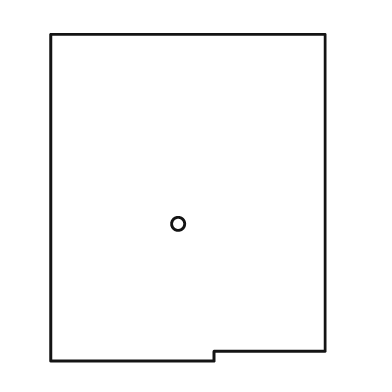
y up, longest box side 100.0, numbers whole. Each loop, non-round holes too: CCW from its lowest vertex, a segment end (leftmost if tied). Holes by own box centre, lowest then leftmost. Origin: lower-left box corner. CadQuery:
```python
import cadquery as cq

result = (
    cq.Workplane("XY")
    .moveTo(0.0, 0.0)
    .lineTo(50.0, 0.0)
    .lineTo(50.0, 3.0)
    .lineTo(84.0, 3.0)
    .lineTo(84.0, 100.0)
    .lineTo(0.0, 100.0)
    .close()
    .moveTo(39.0, 42.0)
    .circle(2.0)
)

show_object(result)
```